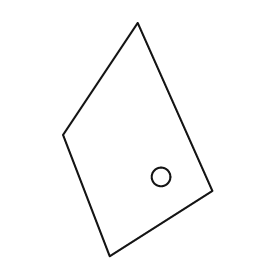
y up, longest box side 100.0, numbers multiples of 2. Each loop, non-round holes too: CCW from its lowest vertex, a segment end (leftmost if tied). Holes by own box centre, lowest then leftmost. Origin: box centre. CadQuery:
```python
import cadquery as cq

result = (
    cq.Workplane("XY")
    .moveTo(-12.0, -50.0)
    .lineTo(32.0, -22.0)
    .lineTo(0.0, 50.0)
    .lineTo(-32.0, 2.0)
    .close()
    .moveTo(10.0, -16.0)
    .circle(4.0)
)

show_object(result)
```